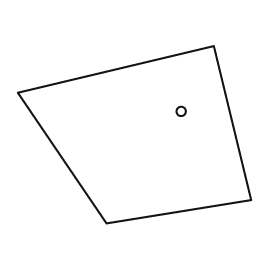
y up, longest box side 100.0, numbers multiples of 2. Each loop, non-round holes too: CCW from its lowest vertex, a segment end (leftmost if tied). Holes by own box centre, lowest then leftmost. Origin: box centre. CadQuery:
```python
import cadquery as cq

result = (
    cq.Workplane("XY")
    .moveTo(-12.0, -38.0)
    .lineTo(50.0, -28.0)
    .lineTo(34.0, 38.0)
    .lineTo(-50.0, 18.0)
    .close()
    .moveTo(20.0, 10.0)
    .circle(2.0)
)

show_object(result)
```